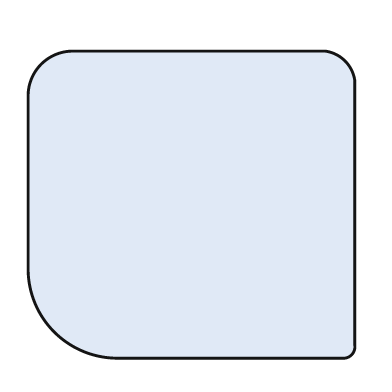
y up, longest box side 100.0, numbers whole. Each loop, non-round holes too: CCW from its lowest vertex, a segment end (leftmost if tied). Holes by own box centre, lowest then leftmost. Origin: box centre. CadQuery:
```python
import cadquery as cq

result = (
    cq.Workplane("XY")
    .moveTo(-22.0, -47.0)
    .lineTo(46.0, -47.0)
    .threePointArc((49.0, -46.0), (50.0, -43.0))
    .lineTo(50.0, 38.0)
    .threePointArc((47.0, 44.0), (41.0, 47.0))
    .lineTo(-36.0, 47.0)
    .threePointArc((-46.0, 43.0), (-50.0, 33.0))
    .lineTo(-50.0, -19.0)
    .threePointArc((-42.0, -39.0), (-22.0, -47.0))
    .close()
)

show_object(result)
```